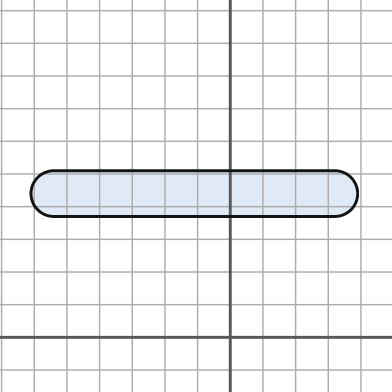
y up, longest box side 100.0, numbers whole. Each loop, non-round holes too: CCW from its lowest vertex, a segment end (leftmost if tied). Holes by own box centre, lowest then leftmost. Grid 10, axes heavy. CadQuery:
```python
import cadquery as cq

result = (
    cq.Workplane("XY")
    .moveTo(-54.0, 37.0)
    .lineTo(32.0, 37.0)
    .threePointArc((39.0, 44.0), (32.0, 51.0))
    .lineTo(-54.0, 51.0)
    .threePointArc((-61.0, 44.0), (-54.0, 37.0))
    .close()
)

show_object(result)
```